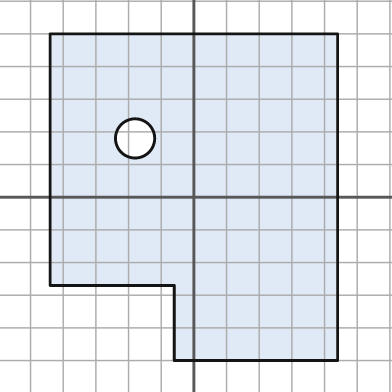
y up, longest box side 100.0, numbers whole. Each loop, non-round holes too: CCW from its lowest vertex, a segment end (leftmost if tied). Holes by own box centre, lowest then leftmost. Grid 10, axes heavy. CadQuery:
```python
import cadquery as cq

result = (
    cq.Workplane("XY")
    .moveTo(-6.0, -50.0)
    .lineTo(44.0, -50.0)
    .lineTo(44.0, 50.0)
    .lineTo(-44.0, 50.0)
    .lineTo(-44.0, -27.0)
    .lineTo(-6.0, -27.0)
    .close()
    .moveTo(-18.0, 18.0)
    .circle(6.0)
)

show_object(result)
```